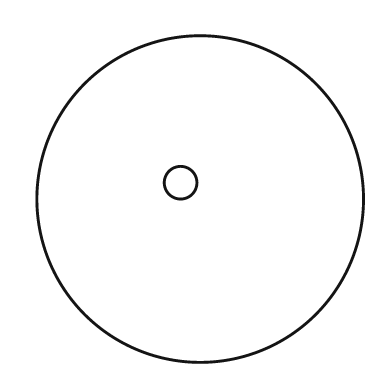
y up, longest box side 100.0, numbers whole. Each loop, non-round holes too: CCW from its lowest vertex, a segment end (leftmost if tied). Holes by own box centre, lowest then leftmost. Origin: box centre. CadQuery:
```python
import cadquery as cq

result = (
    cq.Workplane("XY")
    .moveTo(0.0, 0.0)
    .circle(50.0)
    .moveTo(-6.0, 5.0)
    .circle(5.0)
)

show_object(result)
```